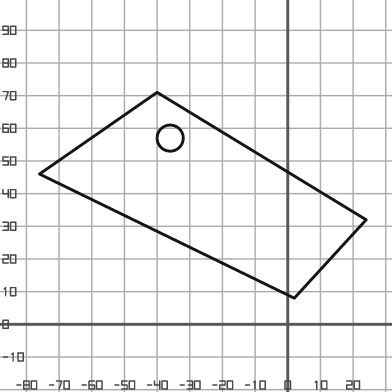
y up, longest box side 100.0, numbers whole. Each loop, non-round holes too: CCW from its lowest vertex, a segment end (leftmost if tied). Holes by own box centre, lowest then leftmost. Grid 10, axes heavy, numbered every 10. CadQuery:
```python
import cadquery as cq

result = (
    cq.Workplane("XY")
    .moveTo(2.0, 8.0)
    .lineTo(24.0, 32.0)
    .lineTo(-40.0, 71.0)
    .lineTo(-76.0, 46.0)
    .close()
    .moveTo(-36.0, 57.0)
    .circle(4.0)
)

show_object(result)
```